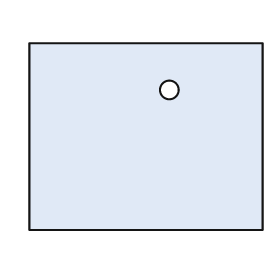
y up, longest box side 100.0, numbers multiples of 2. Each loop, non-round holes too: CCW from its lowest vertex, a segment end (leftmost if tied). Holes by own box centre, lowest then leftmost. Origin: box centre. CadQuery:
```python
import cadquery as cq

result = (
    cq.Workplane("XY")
    .moveTo(-50.0, -40.0)
    .lineTo(50.0, -40.0)
    .lineTo(50.0, 40.0)
    .lineTo(-50.0, 40.0)
    .close()
    .moveTo(10.0, 20.0)
    .circle(4.0)
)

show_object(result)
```